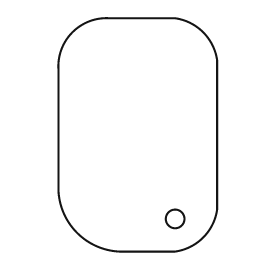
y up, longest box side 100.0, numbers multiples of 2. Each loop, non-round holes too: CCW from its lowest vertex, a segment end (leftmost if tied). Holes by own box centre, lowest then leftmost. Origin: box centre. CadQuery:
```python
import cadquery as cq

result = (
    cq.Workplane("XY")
    .moveTo(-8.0, -50.0)
    .lineTo(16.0, -50.0)
    .threePointArc((28.0, -44.0), (34.0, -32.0))
    .lineTo(34.0, 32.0)
    .threePointArc((28.0, 44.0), (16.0, 50.0))
    .lineTo(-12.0, 50.0)
    .threePointArc((-28.0, 44.0), (-34.0, 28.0))
    .lineTo(-34.0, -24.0)
    .threePointArc((-26.0, -42.0), (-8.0, -50.0))
    .close()
    .moveTo(16.0, -36.0)
    .circle(4.0)
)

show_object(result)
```